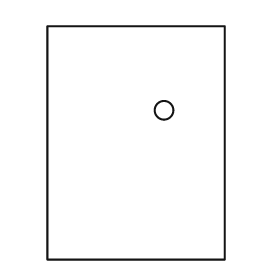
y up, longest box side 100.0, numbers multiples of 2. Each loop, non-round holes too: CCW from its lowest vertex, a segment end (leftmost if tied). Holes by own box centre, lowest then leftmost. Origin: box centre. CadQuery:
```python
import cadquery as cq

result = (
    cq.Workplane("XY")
    .moveTo(-38.0, -50.0)
    .lineTo(38.0, -50.0)
    .lineTo(38.0, 50.0)
    .lineTo(-38.0, 50.0)
    .close()
    .moveTo(12.0, 14.0)
    .circle(4.0)
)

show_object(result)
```